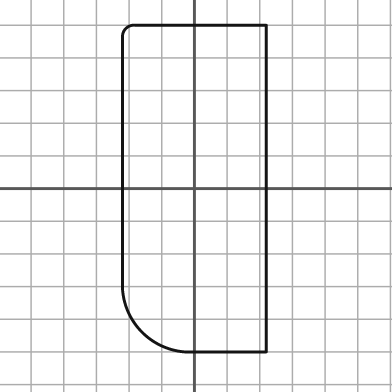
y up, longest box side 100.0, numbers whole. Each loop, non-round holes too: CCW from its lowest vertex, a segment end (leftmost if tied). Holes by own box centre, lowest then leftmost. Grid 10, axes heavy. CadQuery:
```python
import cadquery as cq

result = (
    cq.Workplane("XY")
    .moveTo(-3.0, -50.0)
    .lineTo(22.0, -50.0)
    .lineTo(22.0, 50.0)
    .lineTo(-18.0, 50.0)
    .threePointArc((-21.0, 49.0), (-22.0, 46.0))
    .lineTo(-22.0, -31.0)
    .threePointArc((-16.0, -44.0), (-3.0, -50.0))
    .close()
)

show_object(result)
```